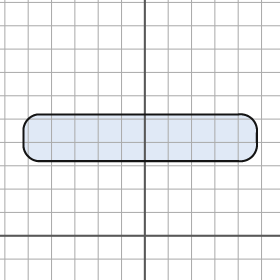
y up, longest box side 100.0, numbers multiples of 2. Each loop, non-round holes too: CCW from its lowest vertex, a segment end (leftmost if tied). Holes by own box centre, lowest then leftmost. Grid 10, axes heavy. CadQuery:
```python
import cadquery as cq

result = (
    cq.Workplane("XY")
    .moveTo(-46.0, 32.0)
    .lineTo(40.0, 32.0)
    .threePointArc((46.0, 34.0), (48.0, 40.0))
    .lineTo(48.0, 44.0)
    .threePointArc((46.0, 50.0), (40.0, 52.0))
    .lineTo(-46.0, 52.0)
    .threePointArc((-50.0, 50.0), (-52.0, 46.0))
    .lineTo(-52.0, 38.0)
    .threePointArc((-50.0, 34.0), (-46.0, 32.0))
    .close()
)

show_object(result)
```